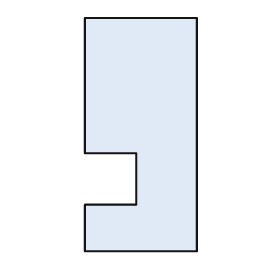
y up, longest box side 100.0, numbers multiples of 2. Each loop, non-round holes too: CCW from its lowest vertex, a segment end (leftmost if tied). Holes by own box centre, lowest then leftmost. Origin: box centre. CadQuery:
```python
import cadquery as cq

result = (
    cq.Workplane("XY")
    .moveTo(-24.0, -50.0)
    .lineTo(24.0, -50.0)
    .lineTo(24.0, 50.0)
    .lineTo(-24.0, 50.0)
    .lineTo(-24.0, -8.0)
    .lineTo(-2.0, -8.0)
    .lineTo(-2.0, -30.0)
    .lineTo(-24.0, -30.0)
    .close()
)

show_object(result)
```